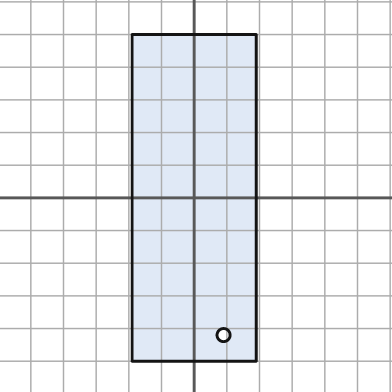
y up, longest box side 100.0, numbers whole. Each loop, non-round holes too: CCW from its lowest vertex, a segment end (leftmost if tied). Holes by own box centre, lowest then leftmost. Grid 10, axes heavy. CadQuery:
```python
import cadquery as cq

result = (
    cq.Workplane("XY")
    .moveTo(-19.0, -50.0)
    .lineTo(19.0, -50.0)
    .lineTo(19.0, 50.0)
    .lineTo(-19.0, 50.0)
    .close()
    .moveTo(9.0, -42.0)
    .circle(2.0)
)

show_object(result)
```